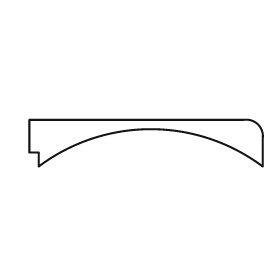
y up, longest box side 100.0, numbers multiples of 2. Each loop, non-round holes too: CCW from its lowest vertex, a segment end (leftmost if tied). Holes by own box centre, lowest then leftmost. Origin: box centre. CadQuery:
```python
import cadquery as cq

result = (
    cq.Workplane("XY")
    .moveTo(-46.0, -10.0)
    .threePointArc((2.0, 6.0), (50.0, -10.0))
    .lineTo(50.0, 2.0)
    .threePointArc((48.0, 8.0), (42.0, 10.0))
    .lineTo(-50.0, 10.0)
    .lineTo(-50.0, -4.0)
    .lineTo(-46.0, -4.0)
    .close()
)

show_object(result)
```